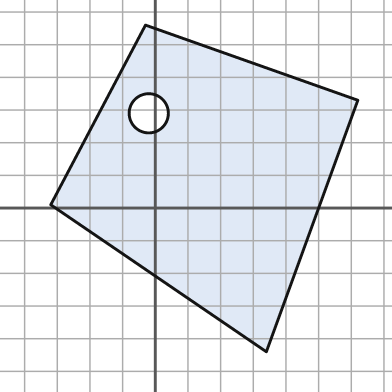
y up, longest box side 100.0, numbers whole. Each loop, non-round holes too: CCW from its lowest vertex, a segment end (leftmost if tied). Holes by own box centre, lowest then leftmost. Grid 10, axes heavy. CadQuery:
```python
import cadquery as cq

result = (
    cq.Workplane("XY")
    .moveTo(34.0, -44.0)
    .lineTo(62.0, 33.0)
    .lineTo(-3.0, 56.0)
    .lineTo(-32.0, 1.0)
    .close()
    .moveTo(-2.0, 29.0)
    .circle(6.0)
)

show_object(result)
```